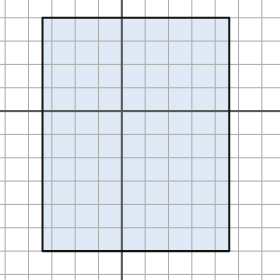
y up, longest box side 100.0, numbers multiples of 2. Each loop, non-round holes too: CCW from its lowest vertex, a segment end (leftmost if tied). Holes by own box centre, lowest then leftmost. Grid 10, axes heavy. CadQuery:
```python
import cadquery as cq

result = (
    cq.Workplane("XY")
    .moveTo(-34.0, -60.0)
    .lineTo(46.0, -60.0)
    .lineTo(46.0, 40.0)
    .lineTo(-34.0, 40.0)
    .close()
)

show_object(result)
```